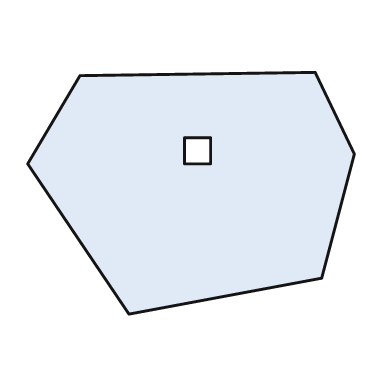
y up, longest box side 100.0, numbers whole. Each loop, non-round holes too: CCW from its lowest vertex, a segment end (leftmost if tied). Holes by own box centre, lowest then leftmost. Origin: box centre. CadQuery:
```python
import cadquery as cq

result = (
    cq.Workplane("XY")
    .moveTo(-19.0, -37.0)
    .lineTo(40.0, -26.0)
    .lineTo(50.0, 12.0)
    .lineTo(38.0, 37.0)
    .lineTo(-34.0, 36.0)
    .lineTo(-50.0, 9.0)
    .close()
    .moveTo(-2.0, 9.0)
    .lineTo(6.0, 9.0)
    .lineTo(6.0, 17.0)
    .lineTo(-2.0, 17.0)
    .close()
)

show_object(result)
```